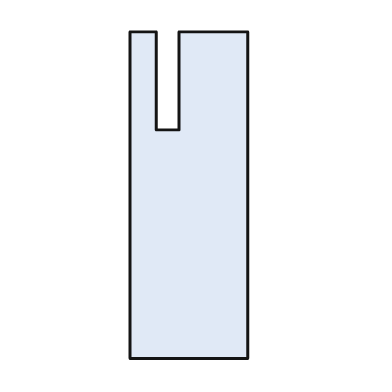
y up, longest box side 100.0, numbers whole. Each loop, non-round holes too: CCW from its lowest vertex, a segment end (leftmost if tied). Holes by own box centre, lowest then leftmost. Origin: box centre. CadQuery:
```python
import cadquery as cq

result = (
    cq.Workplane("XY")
    .moveTo(-18.0, -50.0)
    .lineTo(18.0, -50.0)
    .lineTo(18.0, 50.0)
    .lineTo(-3.0, 50.0)
    .lineTo(-3.0, 20.0)
    .lineTo(-10.0, 20.0)
    .lineTo(-10.0, 50.0)
    .lineTo(-18.0, 50.0)
    .close()
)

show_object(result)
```